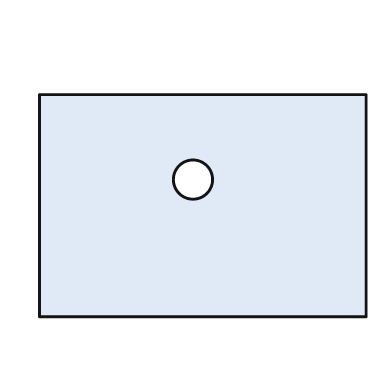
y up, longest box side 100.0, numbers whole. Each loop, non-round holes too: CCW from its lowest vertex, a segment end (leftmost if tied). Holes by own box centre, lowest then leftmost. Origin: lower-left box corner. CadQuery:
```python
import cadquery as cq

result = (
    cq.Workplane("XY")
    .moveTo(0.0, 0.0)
    .lineTo(100.0, 0.0)
    .lineTo(100.0, 68.0)
    .lineTo(0.0, 68.0)
    .close()
    .moveTo(47.0, 42.0)
    .circle(6.0)
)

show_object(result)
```